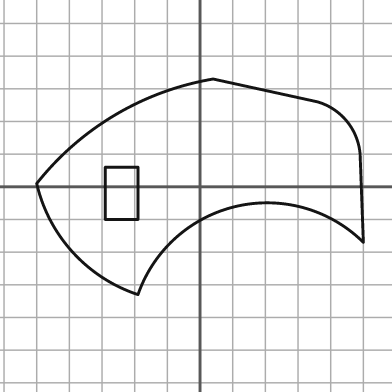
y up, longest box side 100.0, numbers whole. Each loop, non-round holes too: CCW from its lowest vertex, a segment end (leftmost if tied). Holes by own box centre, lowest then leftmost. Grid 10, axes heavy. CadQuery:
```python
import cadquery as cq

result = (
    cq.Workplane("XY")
    .moveTo(-19.0, -33.0)
    .threePointArc((11.0, -6.0), (50.0, -17.0))
    .lineTo(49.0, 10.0)
    .threePointArc((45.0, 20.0), (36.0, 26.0))
    .lineTo(4.0, 33.0)
    .threePointArc((-26.0, 22.0), (-50.0, 1.0))
    .threePointArc((-39.0, -20.0), (-19.0, -33.0))
    .close()
    .moveTo(-29.0, -10.0)
    .lineTo(-19.0, -10.0)
    .lineTo(-19.0, 6.0)
    .lineTo(-29.0, 6.0)
    .close()
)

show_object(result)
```